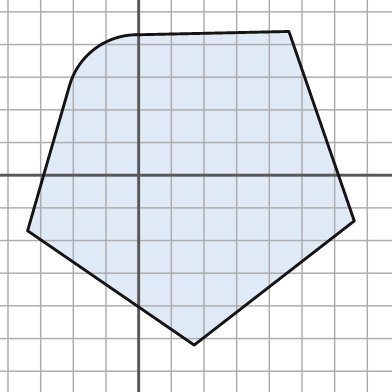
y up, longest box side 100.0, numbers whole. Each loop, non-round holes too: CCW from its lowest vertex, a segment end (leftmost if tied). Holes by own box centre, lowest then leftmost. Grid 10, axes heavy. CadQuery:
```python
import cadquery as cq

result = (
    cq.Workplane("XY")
    .moveTo(17.0, -52.0)
    .lineTo(66.0, -14.0)
    .lineTo(46.0, 44.0)
    .lineTo(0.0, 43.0)
    .threePointArc((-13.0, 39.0), (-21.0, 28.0))
    .lineTo(-34.0, -17.0)
    .close()
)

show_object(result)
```